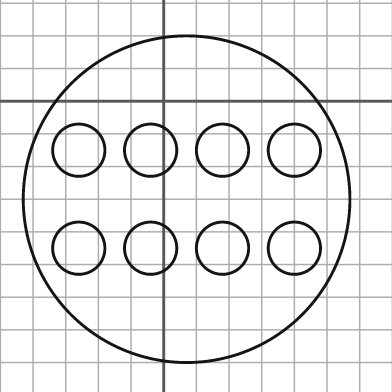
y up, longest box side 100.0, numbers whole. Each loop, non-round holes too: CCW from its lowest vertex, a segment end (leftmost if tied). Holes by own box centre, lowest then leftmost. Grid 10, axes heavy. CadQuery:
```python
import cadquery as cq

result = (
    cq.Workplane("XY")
    .moveTo(7.0, -30.0)
    .circle(50.0)
    .moveTo(-26.0, -45.0)
    .circle(8.0)
    .moveTo(-4.0, -45.0)
    .circle(8.0)
    .moveTo(18.0, -45.0)
    .circle(8.0)
    .moveTo(40.0, -45.0)
    .circle(8.0)
    .moveTo(-26.0, -15.0)
    .circle(8.0)
    .moveTo(-4.0, -15.0)
    .circle(8.0)
    .moveTo(18.0, -15.0)
    .circle(8.0)
    .moveTo(40.0, -15.0)
    .circle(8.0)
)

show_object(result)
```